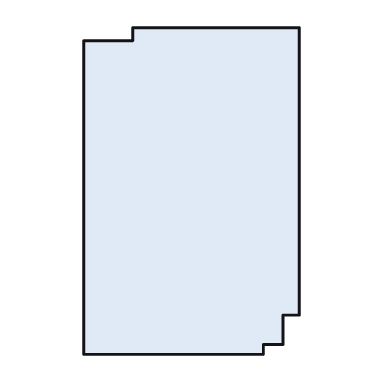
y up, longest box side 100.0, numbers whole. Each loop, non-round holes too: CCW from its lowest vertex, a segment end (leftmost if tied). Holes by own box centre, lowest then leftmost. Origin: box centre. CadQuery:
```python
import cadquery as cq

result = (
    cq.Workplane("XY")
    .moveTo(-33.0, -50.0)
    .lineTo(22.0, -50.0)
    .lineTo(22.0, -47.0)
    .lineTo(28.0, -47.0)
    .lineTo(28.0, -38.0)
    .lineTo(33.0, -38.0)
    .lineTo(33.0, 50.0)
    .lineTo(-18.0, 50.0)
    .lineTo(-18.0, 46.0)
    .lineTo(-33.0, 46.0)
    .close()
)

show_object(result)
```